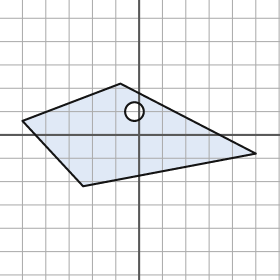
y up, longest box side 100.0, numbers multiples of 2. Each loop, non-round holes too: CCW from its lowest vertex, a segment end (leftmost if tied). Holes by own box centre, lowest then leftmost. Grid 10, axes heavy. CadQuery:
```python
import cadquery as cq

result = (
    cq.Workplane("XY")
    .moveTo(-24.0, -22.0)
    .lineTo(50.0, -8.0)
    .lineTo(-8.0, 22.0)
    .lineTo(-50.0, 6.0)
    .close()
    .moveTo(-2.0, 10.0)
    .circle(4.0)
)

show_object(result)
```